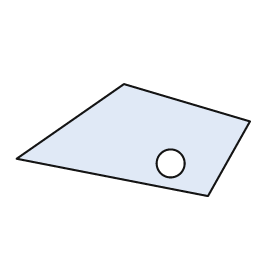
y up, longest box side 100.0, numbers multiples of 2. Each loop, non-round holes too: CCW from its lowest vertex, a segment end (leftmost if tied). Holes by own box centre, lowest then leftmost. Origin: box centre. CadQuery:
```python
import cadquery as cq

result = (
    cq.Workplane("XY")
    .moveTo(32.0, -24.0)
    .lineTo(50.0, 8.0)
    .lineTo(-4.0, 24.0)
    .lineTo(-50.0, -8.0)
    .close()
    .moveTo(16.0, -10.0)
    .circle(6.0)
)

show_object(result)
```